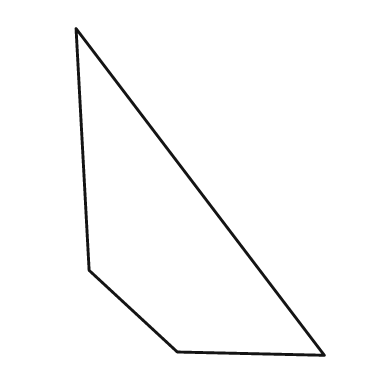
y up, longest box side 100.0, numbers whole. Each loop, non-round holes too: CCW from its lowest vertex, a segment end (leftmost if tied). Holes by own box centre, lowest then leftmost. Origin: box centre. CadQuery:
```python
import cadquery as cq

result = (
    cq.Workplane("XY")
    .moveTo(38.0, -50.0)
    .lineTo(-38.0, 50.0)
    .lineTo(-34.0, -24.0)
    .lineTo(-7.0, -49.0)
    .close()
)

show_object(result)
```